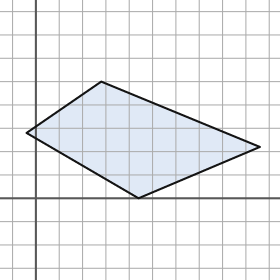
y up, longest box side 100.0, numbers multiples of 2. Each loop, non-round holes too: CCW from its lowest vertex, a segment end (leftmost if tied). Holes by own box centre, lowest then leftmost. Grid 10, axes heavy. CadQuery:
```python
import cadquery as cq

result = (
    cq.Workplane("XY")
    .moveTo(44.0, 0.0)
    .lineTo(96.0, 22.0)
    .lineTo(28.0, 50.0)
    .lineTo(-4.0, 28.0)
    .close()
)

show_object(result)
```